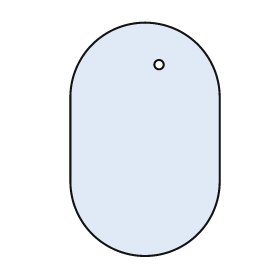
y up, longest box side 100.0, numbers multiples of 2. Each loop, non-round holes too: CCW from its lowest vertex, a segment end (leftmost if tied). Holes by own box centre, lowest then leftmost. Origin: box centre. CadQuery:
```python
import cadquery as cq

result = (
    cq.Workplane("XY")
    .moveTo(-32.0, -18.0)
    .threePointArc((0.0, -50.0), (32.0, -18.0))
    .lineTo(32.0, 18.0)
    .threePointArc((0.0, 50.0), (-32.0, 18.0))
    .close()
    .moveTo(6.0, 32.0)
    .circle(2.0)
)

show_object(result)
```